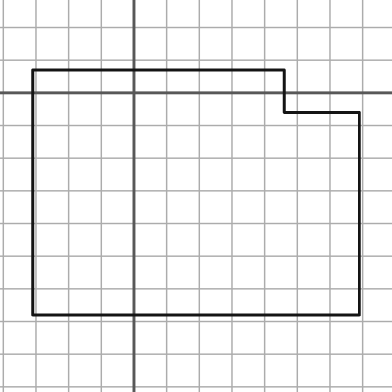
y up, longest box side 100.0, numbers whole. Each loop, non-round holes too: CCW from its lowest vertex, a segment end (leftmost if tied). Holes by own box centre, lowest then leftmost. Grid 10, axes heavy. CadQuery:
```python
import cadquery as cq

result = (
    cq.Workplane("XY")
    .moveTo(-31.0, -68.0)
    .lineTo(69.0, -68.0)
    .lineTo(69.0, -6.0)
    .lineTo(46.0, -6.0)
    .lineTo(46.0, 7.0)
    .lineTo(-31.0, 7.0)
    .close()
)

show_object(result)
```